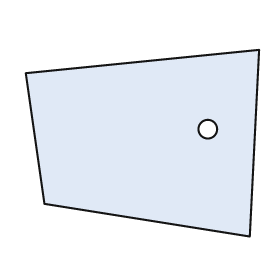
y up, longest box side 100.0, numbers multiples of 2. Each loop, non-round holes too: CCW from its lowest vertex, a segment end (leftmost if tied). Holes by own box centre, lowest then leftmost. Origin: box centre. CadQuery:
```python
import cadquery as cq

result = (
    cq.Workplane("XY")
    .moveTo(46.0, -40.0)
    .lineTo(50.0, 40.0)
    .lineTo(-50.0, 30.0)
    .lineTo(-42.0, -26.0)
    .close()
    .moveTo(28.0, 6.0)
    .circle(4.0)
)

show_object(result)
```